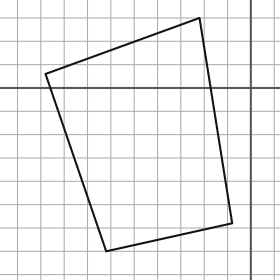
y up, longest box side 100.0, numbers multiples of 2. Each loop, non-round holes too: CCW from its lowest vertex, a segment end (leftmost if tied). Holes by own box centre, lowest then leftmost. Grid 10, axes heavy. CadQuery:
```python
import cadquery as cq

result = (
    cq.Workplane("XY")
    .moveTo(-62.0, -70.0)
    .lineTo(-8.0, -58.0)
    .lineTo(-22.0, 30.0)
    .lineTo(-88.0, 6.0)
    .close()
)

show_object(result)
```